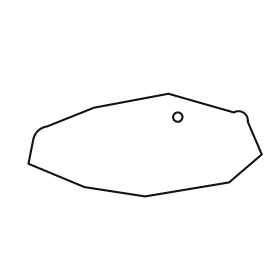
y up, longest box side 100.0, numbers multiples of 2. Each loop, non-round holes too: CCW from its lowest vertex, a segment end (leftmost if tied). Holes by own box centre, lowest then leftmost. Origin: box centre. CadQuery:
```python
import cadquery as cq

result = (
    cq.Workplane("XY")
    .moveTo(0.0, -22.0)
    .lineTo(36.0, -16.0)
    .lineTo(50.0, -4.0)
    .lineTo(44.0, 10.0)
    .threePointArc((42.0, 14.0), (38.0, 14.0))
    .lineTo(10.0, 22.0)
    .lineTo(-22.0, 16.0)
    .lineTo(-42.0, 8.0)
    .threePointArc((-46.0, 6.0), (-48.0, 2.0))
    .lineTo(-50.0, -8.0)
    .lineTo(-26.0, -18.0)
    .close()
    .moveTo(14.0, 12.0)
    .circle(2.0)
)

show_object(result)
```